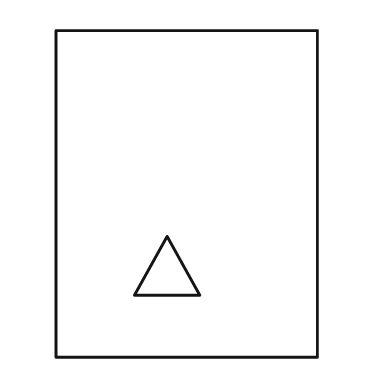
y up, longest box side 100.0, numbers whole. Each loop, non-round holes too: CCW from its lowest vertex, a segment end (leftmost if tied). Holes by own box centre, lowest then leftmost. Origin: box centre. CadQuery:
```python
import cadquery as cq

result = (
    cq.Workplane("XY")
    .moveTo(-40.0, -50.0)
    .lineTo(40.0, -50.0)
    .lineTo(40.0, 50.0)
    .lineTo(-40.0, 50.0)
    .close()
    .moveTo(-16.0, -31.0)
    .lineTo(4.0, -31.0)
    .lineTo(-6.0, -13.0)
    .close()
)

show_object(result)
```